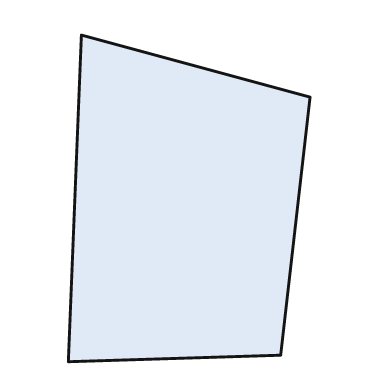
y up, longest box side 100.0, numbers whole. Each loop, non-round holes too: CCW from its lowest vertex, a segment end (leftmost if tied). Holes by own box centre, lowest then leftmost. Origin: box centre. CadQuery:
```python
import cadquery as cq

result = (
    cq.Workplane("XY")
    .moveTo(-37.0, -50.0)
    .lineTo(28.0, -48.0)
    .lineTo(37.0, 31.0)
    .lineTo(-33.0, 50.0)
    .close()
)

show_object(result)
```